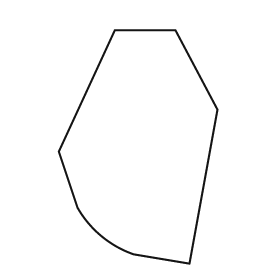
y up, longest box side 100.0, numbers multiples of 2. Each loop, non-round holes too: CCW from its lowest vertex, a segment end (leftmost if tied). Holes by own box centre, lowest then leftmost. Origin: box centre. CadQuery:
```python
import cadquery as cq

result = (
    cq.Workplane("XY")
    .moveTo(22.0, -50.0)
    .lineTo(34.0, 16.0)
    .lineTo(16.0, 50.0)
    .lineTo(-10.0, 50.0)
    .lineTo(-34.0, -2.0)
    .lineTo(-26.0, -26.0)
    .threePointArc((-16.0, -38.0), (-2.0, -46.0))
    .close()
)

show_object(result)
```